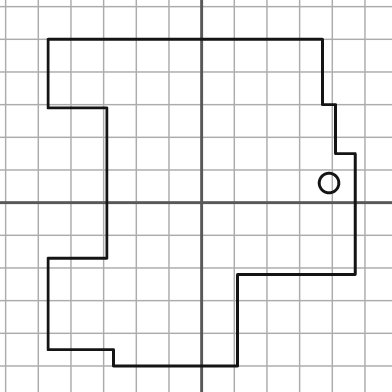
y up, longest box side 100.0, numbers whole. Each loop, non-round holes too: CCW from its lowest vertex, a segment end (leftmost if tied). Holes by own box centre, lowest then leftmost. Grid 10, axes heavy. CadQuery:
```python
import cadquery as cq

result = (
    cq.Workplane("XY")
    .moveTo(-27.0, -50.0)
    .lineTo(11.0, -50.0)
    .lineTo(11.0, -22.0)
    .lineTo(47.0, -22.0)
    .lineTo(47.0, 15.0)
    .lineTo(41.0, 15.0)
    .lineTo(41.0, 30.0)
    .lineTo(37.0, 30.0)
    .lineTo(37.0, 50.0)
    .lineTo(-47.0, 50.0)
    .lineTo(-47.0, 29.0)
    .lineTo(-29.0, 29.0)
    .lineTo(-29.0, -17.0)
    .lineTo(-47.0, -17.0)
    .lineTo(-47.0, -45.0)
    .lineTo(-27.0, -45.0)
    .close()
    .moveTo(39.0, 6.0)
    .circle(3.0)
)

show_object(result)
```